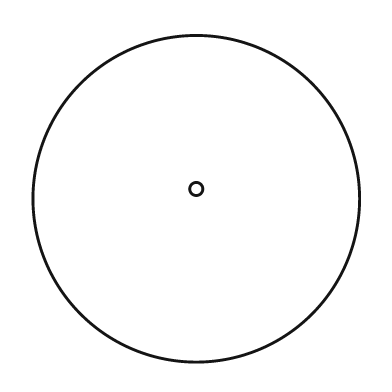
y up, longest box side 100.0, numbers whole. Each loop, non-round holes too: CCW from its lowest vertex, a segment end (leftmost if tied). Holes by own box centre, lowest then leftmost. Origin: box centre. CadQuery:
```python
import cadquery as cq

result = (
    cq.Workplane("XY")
    .moveTo(0.0, 0.0)
    .circle(50.0)
    .moveTo(0.0, 3.0)
    .circle(2.0)
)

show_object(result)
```